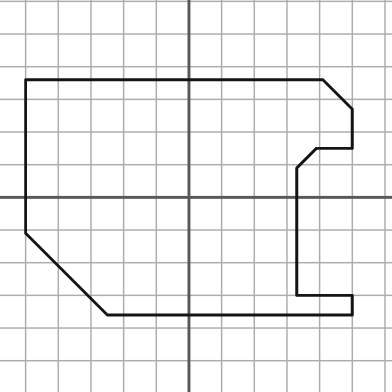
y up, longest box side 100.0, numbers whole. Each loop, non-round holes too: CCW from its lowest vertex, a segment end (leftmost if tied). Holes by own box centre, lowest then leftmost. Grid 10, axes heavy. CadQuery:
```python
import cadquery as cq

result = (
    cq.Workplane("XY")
    .moveTo(-25.0, -36.0)
    .lineTo(50.0, -36.0)
    .lineTo(50.0, -30.0)
    .lineTo(33.0, -30.0)
    .lineTo(33.0, 9.0)
    .lineTo(39.0, 15.0)
    .lineTo(50.0, 15.0)
    .lineTo(50.0, 27.0)
    .lineTo(41.0, 36.0)
    .lineTo(-50.0, 36.0)
    .lineTo(-50.0, -11.0)
    .close()
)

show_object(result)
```